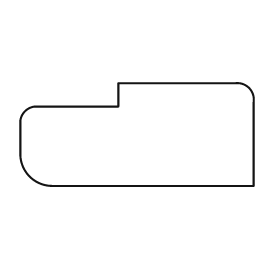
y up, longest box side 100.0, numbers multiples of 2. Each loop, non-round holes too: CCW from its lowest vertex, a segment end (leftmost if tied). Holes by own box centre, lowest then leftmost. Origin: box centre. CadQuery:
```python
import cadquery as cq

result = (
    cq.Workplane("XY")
    .moveTo(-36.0, -22.0)
    .lineTo(50.0, -22.0)
    .lineTo(50.0, 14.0)
    .threePointArc((48.0, 20.0), (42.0, 22.0))
    .lineTo(-8.0, 22.0)
    .lineTo(-8.0, 12.0)
    .lineTo(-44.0, 12.0)
    .threePointArc((-48.0, 10.0), (-50.0, 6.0))
    .lineTo(-50.0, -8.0)
    .threePointArc((-46.0, -18.0), (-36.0, -22.0))
    .close()
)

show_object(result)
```